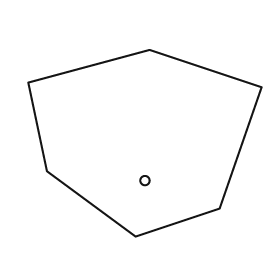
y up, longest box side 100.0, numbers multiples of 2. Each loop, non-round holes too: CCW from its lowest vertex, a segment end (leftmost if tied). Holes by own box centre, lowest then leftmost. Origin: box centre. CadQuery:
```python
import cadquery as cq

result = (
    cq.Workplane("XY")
    .moveTo(-4.0, -40.0)
    .lineTo(32.0, -28.0)
    .lineTo(50.0, 24.0)
    .lineTo(2.0, 40.0)
    .lineTo(-50.0, 26.0)
    .lineTo(-42.0, -12.0)
    .close()
    .moveTo(0.0, -16.0)
    .circle(2.0)
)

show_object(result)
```